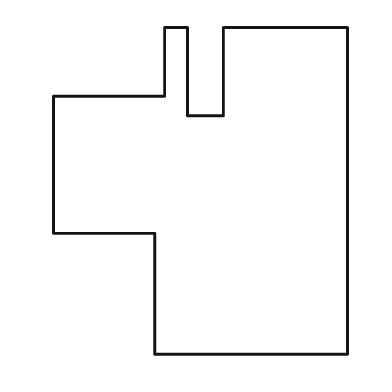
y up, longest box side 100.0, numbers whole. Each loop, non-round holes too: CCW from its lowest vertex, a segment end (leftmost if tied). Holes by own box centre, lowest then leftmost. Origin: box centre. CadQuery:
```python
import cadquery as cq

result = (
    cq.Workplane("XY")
    .moveTo(-14.0, -50.0)
    .lineTo(45.0, -50.0)
    .lineTo(45.0, 50.0)
    .lineTo(7.0, 50.0)
    .lineTo(7.0, 23.0)
    .lineTo(-4.0, 23.0)
    .lineTo(-4.0, 50.0)
    .lineTo(-11.0, 50.0)
    .lineTo(-11.0, 29.0)
    .lineTo(-45.0, 29.0)
    .lineTo(-45.0, -13.0)
    .lineTo(-14.0, -13.0)
    .close()
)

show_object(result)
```